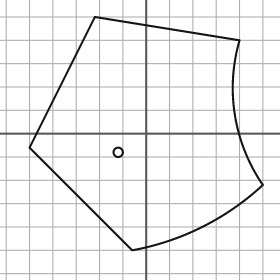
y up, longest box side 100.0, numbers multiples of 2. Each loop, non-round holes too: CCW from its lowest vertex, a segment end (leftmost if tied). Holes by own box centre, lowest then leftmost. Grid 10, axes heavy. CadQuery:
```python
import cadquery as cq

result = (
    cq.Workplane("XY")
    .moveTo(-6.0, -50.0)
    .threePointArc((24.0, -40.0), (50.0, -22.0))
    .threePointArc((38.0, 8.0), (40.0, 40.0))
    .lineTo(-22.0, 50.0)
    .lineTo(-50.0, -6.0)
    .close()
    .moveTo(-12.0, -8.0)
    .circle(2.0)
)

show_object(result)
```